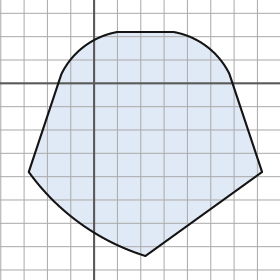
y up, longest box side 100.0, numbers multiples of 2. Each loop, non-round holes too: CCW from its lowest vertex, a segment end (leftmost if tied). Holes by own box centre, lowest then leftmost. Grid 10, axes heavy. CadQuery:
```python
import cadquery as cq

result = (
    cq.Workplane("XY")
    .moveTo(22.0, -74.0)
    .lineTo(72.0, -38.0)
    .lineTo(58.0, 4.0)
    .threePointArc((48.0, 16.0), (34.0, 22.0))
    .lineTo(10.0, 22.0)
    .threePointArc((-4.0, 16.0), (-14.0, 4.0))
    .lineTo(-28.0, -38.0)
    .threePointArc((-6.0, -60.0), (22.0, -74.0))
    .close()
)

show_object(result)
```